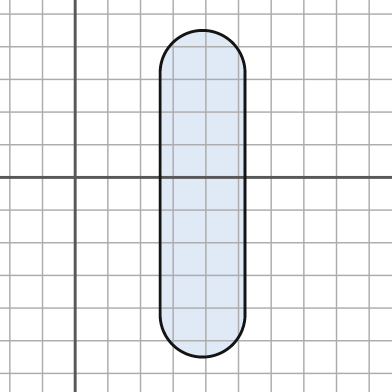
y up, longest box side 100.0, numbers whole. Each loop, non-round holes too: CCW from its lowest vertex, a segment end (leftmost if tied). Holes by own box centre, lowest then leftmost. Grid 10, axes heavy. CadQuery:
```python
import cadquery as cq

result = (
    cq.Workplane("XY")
    .moveTo(26.0, -42.0)
    .threePointArc((39.0, -55.0), (52.0, -42.0))
    .lineTo(52.0, 32.0)
    .threePointArc((39.0, 45.0), (26.0, 32.0))
    .close()
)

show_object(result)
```